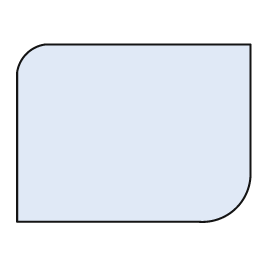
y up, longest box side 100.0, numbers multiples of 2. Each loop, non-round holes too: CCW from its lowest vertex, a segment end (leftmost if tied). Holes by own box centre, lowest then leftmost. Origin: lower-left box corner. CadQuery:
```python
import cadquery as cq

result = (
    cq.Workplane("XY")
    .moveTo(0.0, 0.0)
    .lineTo(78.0, 0.0)
    .threePointArc((94.0, 6.0), (100.0, 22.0))
    .lineTo(100.0, 76.0)
    .lineTo(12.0, 76.0)
    .threePointArc((4.0, 72.0), (0.0, 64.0))
    .close()
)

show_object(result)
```